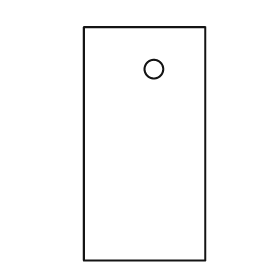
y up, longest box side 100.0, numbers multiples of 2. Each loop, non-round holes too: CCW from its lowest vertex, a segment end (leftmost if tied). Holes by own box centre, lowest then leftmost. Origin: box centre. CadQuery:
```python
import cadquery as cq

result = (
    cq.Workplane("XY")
    .moveTo(-26.0, -50.0)
    .lineTo(26.0, -50.0)
    .lineTo(26.0, 50.0)
    .lineTo(-26.0, 50.0)
    .close()
    .moveTo(4.0, 32.0)
    .circle(4.0)
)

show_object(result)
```